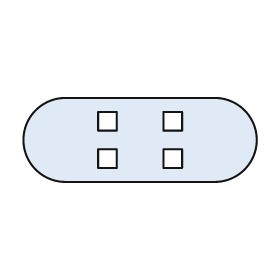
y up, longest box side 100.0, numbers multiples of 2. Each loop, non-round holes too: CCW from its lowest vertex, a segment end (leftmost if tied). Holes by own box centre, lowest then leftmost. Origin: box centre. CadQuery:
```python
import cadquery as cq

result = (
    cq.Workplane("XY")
    .moveTo(-32.0, -18.0)
    .lineTo(32.0, -18.0)
    .threePointArc((50.0, 0.0), (32.0, 18.0))
    .lineTo(-32.0, 18.0)
    .threePointArc((-50.0, 0.0), (-32.0, -18.0))
    .close()
    .moveTo(-18.0, -12.0)
    .lineTo(-10.0, -12.0)
    .lineTo(-10.0, -4.0)
    .lineTo(-18.0, -4.0)
    .close()
    .moveTo(10.0, -12.0)
    .lineTo(18.0, -12.0)
    .lineTo(18.0, -4.0)
    .lineTo(10.0, -4.0)
    .close()
    .moveTo(-18.0, 4.0)
    .lineTo(-10.0, 4.0)
    .lineTo(-10.0, 12.0)
    .lineTo(-18.0, 12.0)
    .close()
    .moveTo(10.0, 4.0)
    .lineTo(18.0, 4.0)
    .lineTo(18.0, 12.0)
    .lineTo(10.0, 12.0)
    .close()
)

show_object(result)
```